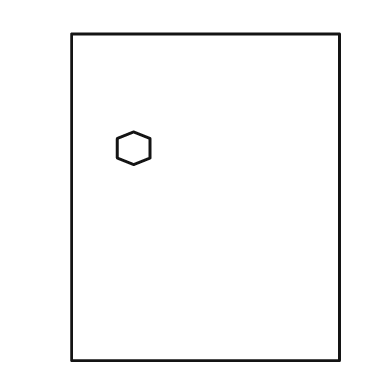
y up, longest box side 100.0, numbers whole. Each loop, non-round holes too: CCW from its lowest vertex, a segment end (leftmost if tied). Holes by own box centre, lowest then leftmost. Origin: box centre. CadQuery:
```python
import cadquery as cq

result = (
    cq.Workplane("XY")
    .moveTo(-41.0, -50.0)
    .lineTo(41.0, -50.0)
    .lineTo(41.0, 50.0)
    .lineTo(-41.0, 50.0)
    .close()
    .moveTo(-22.0, 10.0)
    .lineTo(-17.0, 12.0)
    .lineTo(-17.0, 18.0)
    .lineTo(-22.0, 20.0)
    .lineTo(-27.0, 18.0)
    .lineTo(-27.0, 12.0)
    .close()
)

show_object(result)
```